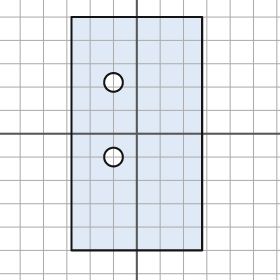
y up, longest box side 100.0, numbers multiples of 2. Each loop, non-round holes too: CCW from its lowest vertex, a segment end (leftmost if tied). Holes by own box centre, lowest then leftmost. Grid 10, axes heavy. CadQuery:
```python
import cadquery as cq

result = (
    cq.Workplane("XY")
    .moveTo(-28.0, -50.0)
    .lineTo(28.0, -50.0)
    .lineTo(28.0, 50.0)
    .lineTo(-28.0, 50.0)
    .close()
    .moveTo(-10.0, -10.0)
    .circle(4.0)
    .moveTo(-10.0, 22.0)
    .circle(4.0)
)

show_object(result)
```